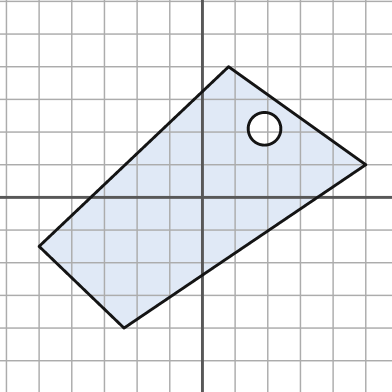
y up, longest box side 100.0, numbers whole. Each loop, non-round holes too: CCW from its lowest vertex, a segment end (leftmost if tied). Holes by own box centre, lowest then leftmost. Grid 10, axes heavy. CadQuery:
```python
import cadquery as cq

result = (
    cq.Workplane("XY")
    .moveTo(-24.0, -40.0)
    .lineTo(50.0, 10.0)
    .lineTo(8.0, 40.0)
    .lineTo(-50.0, -15.0)
    .close()
    .moveTo(19.0, 21.0)
    .circle(5.0)
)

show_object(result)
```